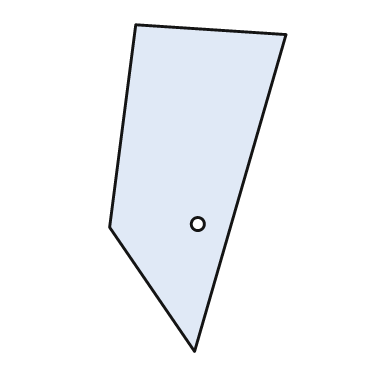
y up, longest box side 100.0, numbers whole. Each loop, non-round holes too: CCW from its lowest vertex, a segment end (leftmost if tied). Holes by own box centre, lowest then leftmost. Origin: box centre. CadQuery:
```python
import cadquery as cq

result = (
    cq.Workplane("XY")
    .moveTo(-1.0, -50.0)
    .lineTo(27.0, 47.0)
    .lineTo(-19.0, 50.0)
    .lineTo(-27.0, -12.0)
    .close()
    .moveTo(0.0, -11.0)
    .circle(2.0)
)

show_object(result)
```